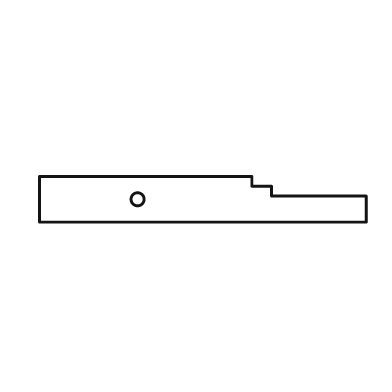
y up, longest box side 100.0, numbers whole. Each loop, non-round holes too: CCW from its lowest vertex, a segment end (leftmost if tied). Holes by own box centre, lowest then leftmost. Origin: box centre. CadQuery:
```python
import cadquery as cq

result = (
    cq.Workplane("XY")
    .moveTo(-50.0, -7.0)
    .lineTo(50.0, -7.0)
    .lineTo(50.0, 1.0)
    .lineTo(21.0, 1.0)
    .lineTo(21.0, 4.0)
    .lineTo(15.0, 4.0)
    .lineTo(15.0, 7.0)
    .lineTo(-50.0, 7.0)
    .close()
    .moveTo(-20.0, 0.0)
    .circle(2.0)
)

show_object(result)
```